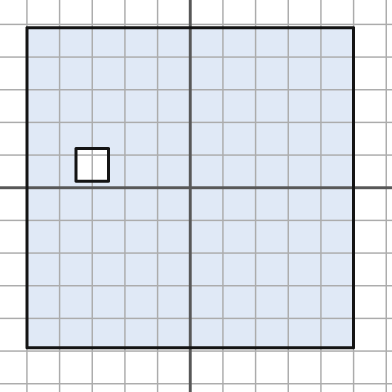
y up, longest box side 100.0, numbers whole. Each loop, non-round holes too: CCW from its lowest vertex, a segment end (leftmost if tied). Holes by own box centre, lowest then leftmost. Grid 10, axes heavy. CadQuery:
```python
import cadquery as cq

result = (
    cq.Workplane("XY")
    .moveTo(-50.0, -49.0)
    .lineTo(50.0, -49.0)
    .lineTo(50.0, 49.0)
    .lineTo(-50.0, 49.0)
    .close()
    .moveTo(-35.0, 2.0)
    .lineTo(-25.0, 2.0)
    .lineTo(-25.0, 12.0)
    .lineTo(-35.0, 12.0)
    .close()
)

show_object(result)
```